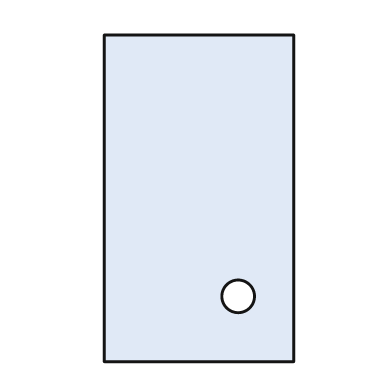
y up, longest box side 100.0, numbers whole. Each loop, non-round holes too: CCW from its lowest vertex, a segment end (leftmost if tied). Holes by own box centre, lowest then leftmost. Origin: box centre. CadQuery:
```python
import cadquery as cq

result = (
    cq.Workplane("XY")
    .moveTo(-29.0, -50.0)
    .lineTo(29.0, -50.0)
    .lineTo(29.0, 50.0)
    .lineTo(-29.0, 50.0)
    .close()
    .moveTo(12.0, -30.0)
    .circle(5.0)
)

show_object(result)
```